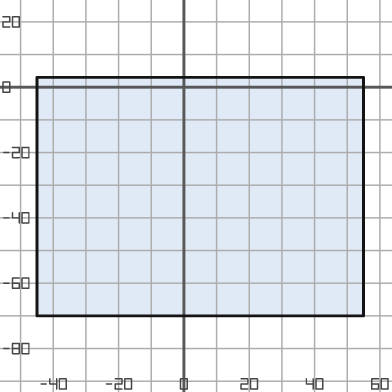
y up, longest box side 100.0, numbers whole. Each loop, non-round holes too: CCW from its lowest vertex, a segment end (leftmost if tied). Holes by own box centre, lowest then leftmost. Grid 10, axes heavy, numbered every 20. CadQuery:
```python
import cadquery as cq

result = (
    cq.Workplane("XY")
    .moveTo(-45.0, -70.0)
    .lineTo(55.0, -70.0)
    .lineTo(55.0, 3.0)
    .lineTo(-45.0, 3.0)
    .close()
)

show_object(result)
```